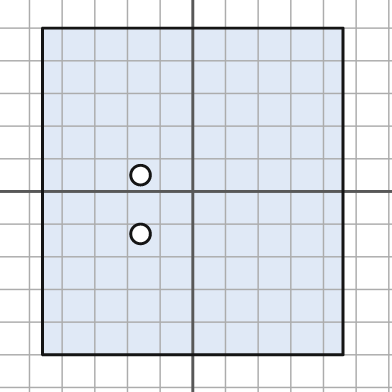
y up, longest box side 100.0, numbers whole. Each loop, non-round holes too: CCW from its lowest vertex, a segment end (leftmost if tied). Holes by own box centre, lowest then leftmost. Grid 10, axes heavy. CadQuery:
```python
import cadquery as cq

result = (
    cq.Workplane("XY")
    .moveTo(-46.0, -50.0)
    .lineTo(46.0, -50.0)
    .lineTo(46.0, 50.0)
    .lineTo(-46.0, 50.0)
    .close()
    .moveTo(-16.0, -13.0)
    .circle(3.0)
    .moveTo(-16.0, 5.0)
    .circle(3.0)
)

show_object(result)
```